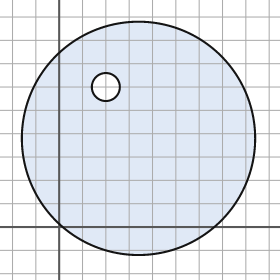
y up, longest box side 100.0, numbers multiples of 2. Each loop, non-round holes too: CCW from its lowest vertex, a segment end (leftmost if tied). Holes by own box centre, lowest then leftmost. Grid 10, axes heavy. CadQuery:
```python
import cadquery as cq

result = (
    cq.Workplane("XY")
    .moveTo(34.0, 38.0)
    .circle(50.0)
    .moveTo(20.0, 60.0)
    .circle(6.0)
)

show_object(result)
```